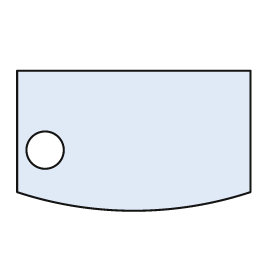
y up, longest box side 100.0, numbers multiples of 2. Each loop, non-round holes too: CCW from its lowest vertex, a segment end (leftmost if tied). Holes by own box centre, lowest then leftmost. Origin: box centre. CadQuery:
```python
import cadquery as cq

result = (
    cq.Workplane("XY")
    .moveTo(-50.0, -22.0)
    .threePointArc((0.0, -30.0), (50.0, -22.0))
    .lineTo(50.0, 30.0)
    .lineTo(-50.0, 30.0)
    .close()
    .moveTo(-38.0, -4.0)
    .circle(8.0)
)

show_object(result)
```